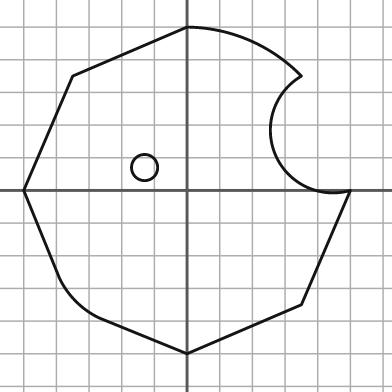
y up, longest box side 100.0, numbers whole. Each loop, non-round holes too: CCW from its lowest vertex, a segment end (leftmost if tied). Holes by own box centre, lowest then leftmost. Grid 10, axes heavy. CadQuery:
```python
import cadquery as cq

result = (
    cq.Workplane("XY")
    .moveTo(0.0, -50.0)
    .lineTo(35.0, -35.0)
    .lineTo(50.0, 0.0)
    .threePointArc((27.0, 11.0), (35.0, 35.0))
    .threePointArc((19.0, 46.0), (0.0, 50.0))
    .lineTo(-35.0, 35.0)
    .lineTo(-50.0, 0.0)
    .lineTo(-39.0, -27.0)
    .threePointArc((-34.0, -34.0), (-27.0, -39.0))
    .close()
    .moveTo(-13.0, 7.0)
    .circle(4.0)
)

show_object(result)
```